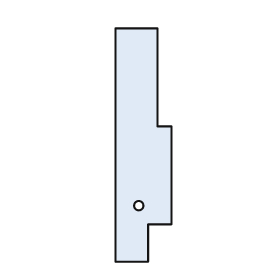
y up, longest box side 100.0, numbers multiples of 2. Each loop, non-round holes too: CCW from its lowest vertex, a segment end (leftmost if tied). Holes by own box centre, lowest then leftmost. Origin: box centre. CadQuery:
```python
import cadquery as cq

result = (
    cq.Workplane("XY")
    .moveTo(-12.0, -50.0)
    .lineTo(2.0, -50.0)
    .lineTo(2.0, -34.0)
    .lineTo(12.0, -34.0)
    .lineTo(12.0, 8.0)
    .lineTo(6.0, 8.0)
    .lineTo(6.0, 50.0)
    .lineTo(-12.0, 50.0)
    .close()
    .moveTo(-2.0, -26.0)
    .circle(2.0)
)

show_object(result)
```